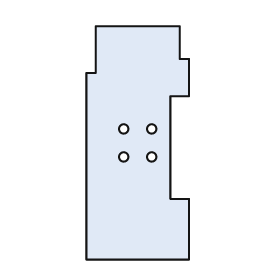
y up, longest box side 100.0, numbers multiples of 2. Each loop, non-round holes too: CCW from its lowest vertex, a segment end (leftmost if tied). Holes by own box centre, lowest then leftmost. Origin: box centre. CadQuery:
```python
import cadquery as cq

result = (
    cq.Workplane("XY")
    .moveTo(-22.0, -50.0)
    .lineTo(22.0, -50.0)
    .lineTo(22.0, -24.0)
    .lineTo(14.0, -24.0)
    .lineTo(14.0, 20.0)
    .lineTo(22.0, 20.0)
    .lineTo(22.0, 36.0)
    .lineTo(18.0, 36.0)
    .lineTo(18.0, 50.0)
    .lineTo(-18.0, 50.0)
    .lineTo(-18.0, 30.0)
    .lineTo(-22.0, 30.0)
    .close()
    .moveTo(-6.0, -6.0)
    .circle(2.0)
    .moveTo(6.0, -6.0)
    .circle(2.0)
    .moveTo(-6.0, 6.0)
    .circle(2.0)
    .moveTo(6.0, 6.0)
    .circle(2.0)
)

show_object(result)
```